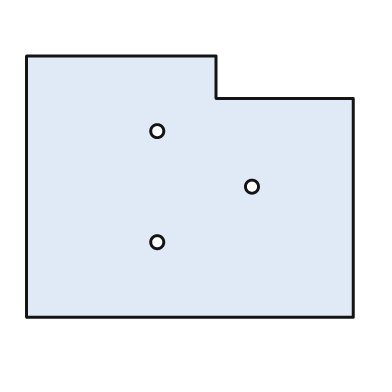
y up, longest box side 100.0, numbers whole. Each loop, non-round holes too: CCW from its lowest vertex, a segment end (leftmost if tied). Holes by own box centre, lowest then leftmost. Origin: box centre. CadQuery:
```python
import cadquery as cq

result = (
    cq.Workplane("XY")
    .moveTo(-50.0, -40.0)
    .lineTo(50.0, -40.0)
    .lineTo(50.0, 27.0)
    .lineTo(8.0, 27.0)
    .lineTo(8.0, 40.0)
    .lineTo(-50.0, 40.0)
    .close()
    .moveTo(-10.0, -17.0)
    .circle(2.0)
    .moveTo(19.0, 0.0)
    .circle(2.0)
    .moveTo(-10.0, 17.0)
    .circle(2.0)
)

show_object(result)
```